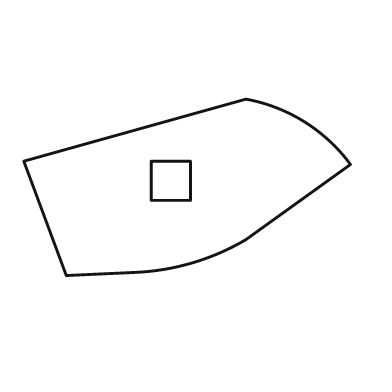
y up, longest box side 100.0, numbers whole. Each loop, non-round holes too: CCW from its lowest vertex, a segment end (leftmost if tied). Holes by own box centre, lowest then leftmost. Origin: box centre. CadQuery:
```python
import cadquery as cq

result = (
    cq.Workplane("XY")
    .moveTo(-37.0, -27.0)
    .lineTo(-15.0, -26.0)
    .threePointArc((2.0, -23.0), (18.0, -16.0))
    .lineTo(50.0, 7.0)
    .threePointArc((36.0, 20.0), (18.0, 27.0))
    .lineTo(-50.0, 8.0)
    .close()
    .moveTo(-11.0, -4.0)
    .lineTo(1.0, -4.0)
    .lineTo(1.0, 8.0)
    .lineTo(-11.0, 8.0)
    .close()
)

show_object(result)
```